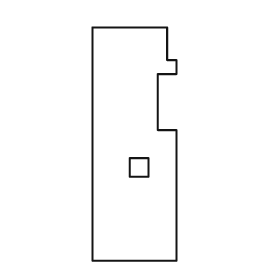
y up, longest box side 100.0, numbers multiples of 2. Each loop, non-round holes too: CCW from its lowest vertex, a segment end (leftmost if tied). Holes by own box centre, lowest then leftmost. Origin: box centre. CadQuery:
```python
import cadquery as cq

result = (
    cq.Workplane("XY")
    .moveTo(-18.0, -50.0)
    .lineTo(18.0, -50.0)
    .lineTo(18.0, 6.0)
    .lineTo(10.0, 6.0)
    .lineTo(10.0, 30.0)
    .lineTo(18.0, 30.0)
    .lineTo(18.0, 36.0)
    .lineTo(14.0, 36.0)
    .lineTo(14.0, 50.0)
    .lineTo(-18.0, 50.0)
    .close()
    .moveTo(-2.0, -14.0)
    .lineTo(6.0, -14.0)
    .lineTo(6.0, -6.0)
    .lineTo(-2.0, -6.0)
    .close()
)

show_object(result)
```